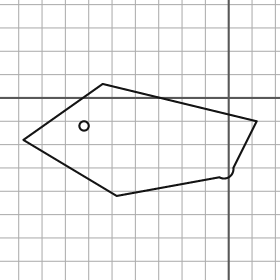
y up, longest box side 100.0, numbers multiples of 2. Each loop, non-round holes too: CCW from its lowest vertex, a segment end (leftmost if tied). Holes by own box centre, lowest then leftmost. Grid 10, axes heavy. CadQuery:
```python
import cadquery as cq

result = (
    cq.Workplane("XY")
    .moveTo(-48.0, -42.0)
    .lineTo(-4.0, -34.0)
    .threePointArc((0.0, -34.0), (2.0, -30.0))
    .lineTo(12.0, -10.0)
    .lineTo(-54.0, 6.0)
    .lineTo(-88.0, -18.0)
    .close()
    .moveTo(-62.0, -12.0)
    .circle(2.0)
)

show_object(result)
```